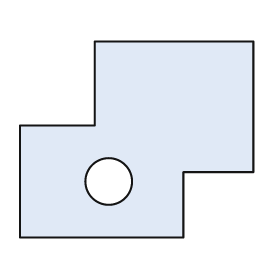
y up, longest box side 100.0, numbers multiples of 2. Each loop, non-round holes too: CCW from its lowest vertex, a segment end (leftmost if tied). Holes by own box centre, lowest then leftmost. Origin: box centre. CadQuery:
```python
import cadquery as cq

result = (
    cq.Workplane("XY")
    .moveTo(-50.0, -42.0)
    .lineTo(20.0, -42.0)
    .lineTo(20.0, -14.0)
    .lineTo(50.0, -14.0)
    .lineTo(50.0, 42.0)
    .lineTo(-18.0, 42.0)
    .lineTo(-18.0, 6.0)
    .lineTo(-50.0, 6.0)
    .close()
    .moveTo(-12.0, -18.0)
    .circle(10.0)
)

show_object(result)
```